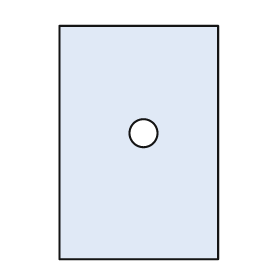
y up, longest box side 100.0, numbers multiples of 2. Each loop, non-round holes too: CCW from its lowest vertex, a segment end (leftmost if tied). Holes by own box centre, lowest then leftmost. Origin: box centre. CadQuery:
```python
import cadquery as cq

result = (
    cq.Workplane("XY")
    .moveTo(-34.0, -50.0)
    .lineTo(34.0, -50.0)
    .lineTo(34.0, 50.0)
    .lineTo(-34.0, 50.0)
    .close()
    .moveTo(2.0, 4.0)
    .circle(6.0)
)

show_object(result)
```